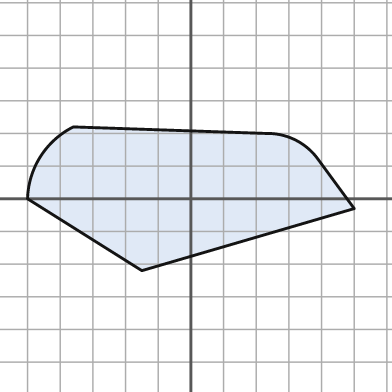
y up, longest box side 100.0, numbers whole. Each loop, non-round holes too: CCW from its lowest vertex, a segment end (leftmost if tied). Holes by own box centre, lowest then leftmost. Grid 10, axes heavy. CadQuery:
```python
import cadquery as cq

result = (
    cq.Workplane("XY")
    .moveTo(-15.0, -22.0)
    .lineTo(50.0, -3.0)
    .lineTo(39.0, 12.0)
    .threePointArc((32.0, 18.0), (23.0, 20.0))
    .lineTo(-36.0, 22.0)
    .threePointArc((-46.0, 13.0), (-50.0, 0.0))
    .close()
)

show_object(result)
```